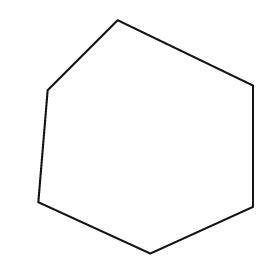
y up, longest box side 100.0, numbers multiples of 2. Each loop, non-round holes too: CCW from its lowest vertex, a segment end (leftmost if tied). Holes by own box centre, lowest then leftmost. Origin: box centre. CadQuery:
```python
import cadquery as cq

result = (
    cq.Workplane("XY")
    .moveTo(2.0, -50.0)
    .lineTo(46.0, -30.0)
    .lineTo(46.0, 22.0)
    .lineTo(-12.0, 50.0)
    .lineTo(-42.0, 20.0)
    .lineTo(-46.0, -28.0)
    .close()
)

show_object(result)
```